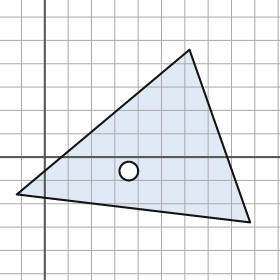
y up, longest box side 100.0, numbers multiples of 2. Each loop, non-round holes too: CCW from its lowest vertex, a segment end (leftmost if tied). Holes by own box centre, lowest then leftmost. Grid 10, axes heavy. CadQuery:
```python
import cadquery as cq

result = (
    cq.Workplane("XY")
    .moveTo(88.0, -28.0)
    .lineTo(62.0, 46.0)
    .lineTo(-12.0, -16.0)
    .close()
    .moveTo(36.0, -6.0)
    .circle(4.0)
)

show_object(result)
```